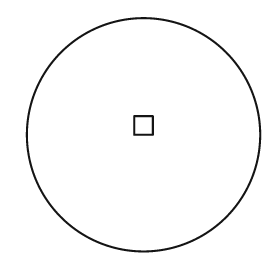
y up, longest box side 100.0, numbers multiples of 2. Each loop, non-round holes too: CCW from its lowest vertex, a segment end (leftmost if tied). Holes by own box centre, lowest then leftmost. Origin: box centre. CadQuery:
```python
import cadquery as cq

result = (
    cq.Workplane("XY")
    .moveTo(0.0, 0.0)
    .circle(50.0)
    .moveTo(-4.0, 0.0)
    .lineTo(4.0, 0.0)
    .lineTo(4.0, 8.0)
    .lineTo(-4.0, 8.0)
    .close()
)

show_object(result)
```